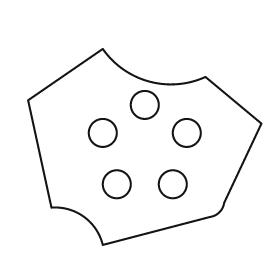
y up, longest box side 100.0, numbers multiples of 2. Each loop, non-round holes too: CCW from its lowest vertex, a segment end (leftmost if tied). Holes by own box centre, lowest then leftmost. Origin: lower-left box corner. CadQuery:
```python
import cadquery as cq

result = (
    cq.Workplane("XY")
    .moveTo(32.0, 0.0)
    .lineTo(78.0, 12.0)
    .threePointArc((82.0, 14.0), (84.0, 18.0))
    .lineTo(100.0, 52.0)
    .lineTo(76.0, 72.0)
    .threePointArc((52.0, 70.0), (32.0, 84.0))
    .lineTo(0.0, 62.0)
    .lineTo(10.0, 16.0)
    .threePointArc((24.0, 12.0), (32.0, 0.0))
    .close()
    .moveTo(38.0, 26.0)
    .circle(6.0)
    .moveTo(62.0, 26.0)
    .circle(6.0)
    .moveTo(32.0, 48.0)
    .circle(6.0)
    .moveTo(68.0, 48.0)
    .circle(6.0)
    .moveTo(50.0, 60.0)
    .circle(6.0)
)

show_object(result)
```